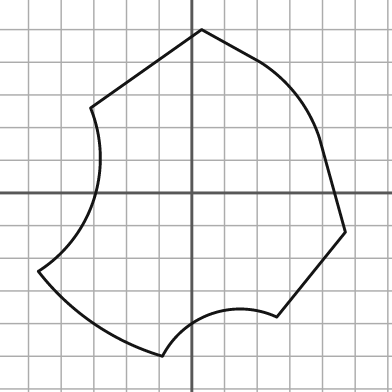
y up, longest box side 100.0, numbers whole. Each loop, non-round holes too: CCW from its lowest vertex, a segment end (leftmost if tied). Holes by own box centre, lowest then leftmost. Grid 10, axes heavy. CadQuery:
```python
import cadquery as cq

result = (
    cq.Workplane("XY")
    .moveTo(-9.0, -50.0)
    .threePointArc((6.0, -37.0), (26.0, -38.0))
    .lineTo(47.0, -12.0)
    .lineTo(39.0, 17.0)
    .threePointArc((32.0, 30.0), (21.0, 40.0))
    .lineTo(3.0, 50.0)
    .lineTo(-31.0, 26.0)
    .threePointArc((-30.0, -2.0), (-47.0, -24.0))
    .threePointArc((-30.0, -40.0), (-9.0, -50.0))
    .close()
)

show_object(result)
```